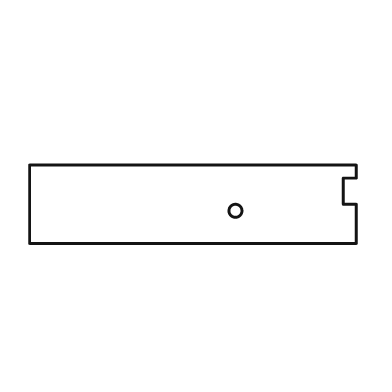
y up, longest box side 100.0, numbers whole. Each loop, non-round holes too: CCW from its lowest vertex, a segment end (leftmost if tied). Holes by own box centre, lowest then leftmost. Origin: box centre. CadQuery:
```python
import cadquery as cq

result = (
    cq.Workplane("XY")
    .moveTo(-50.0, -12.0)
    .lineTo(50.0, -12.0)
    .lineTo(50.0, 0.0)
    .lineTo(46.0, 0.0)
    .lineTo(46.0, 8.0)
    .lineTo(50.0, 8.0)
    .lineTo(50.0, 12.0)
    .lineTo(-50.0, 12.0)
    .close()
    .moveTo(13.0, -2.0)
    .circle(2.0)
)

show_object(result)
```